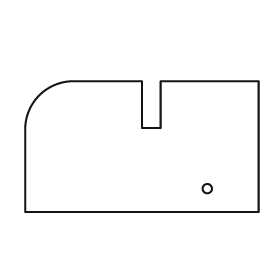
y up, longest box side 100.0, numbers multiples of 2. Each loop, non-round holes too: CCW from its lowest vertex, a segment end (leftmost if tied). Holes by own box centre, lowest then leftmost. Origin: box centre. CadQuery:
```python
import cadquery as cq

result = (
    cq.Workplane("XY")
    .moveTo(-50.0, -28.0)
    .lineTo(50.0, -28.0)
    .lineTo(50.0, 28.0)
    .lineTo(8.0, 28.0)
    .lineTo(8.0, 8.0)
    .lineTo(0.0, 8.0)
    .lineTo(0.0, 28.0)
    .lineTo(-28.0, 28.0)
    .threePointArc((-44.0, 22.0), (-50.0, 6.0))
    .close()
    .moveTo(28.0, -18.0)
    .circle(2.0)
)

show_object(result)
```